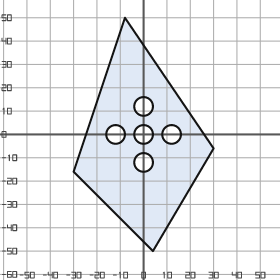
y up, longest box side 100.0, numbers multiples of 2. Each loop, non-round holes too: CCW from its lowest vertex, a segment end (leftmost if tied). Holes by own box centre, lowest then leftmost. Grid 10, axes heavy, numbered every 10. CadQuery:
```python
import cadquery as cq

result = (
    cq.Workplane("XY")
    .moveTo(4.0, -50.0)
    .lineTo(30.0, -6.0)
    .lineTo(-8.0, 50.0)
    .lineTo(-30.0, -16.0)
    .close()
    .moveTo(0.0, -12.0)
    .circle(4.0)
    .moveTo(-12.0, 0.0)
    .circle(4.0)
    .moveTo(0.0, 0.0)
    .circle(4.0)
    .moveTo(12.0, 0.0)
    .circle(4.0)
    .moveTo(0.0, 12.0)
    .circle(4.0)
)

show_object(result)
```